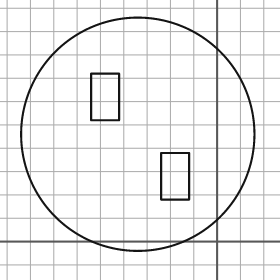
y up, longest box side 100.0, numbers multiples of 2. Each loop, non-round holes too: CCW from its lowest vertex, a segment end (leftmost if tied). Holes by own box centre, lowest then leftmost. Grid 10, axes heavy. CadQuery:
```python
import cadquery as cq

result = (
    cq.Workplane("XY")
    .moveTo(-34.0, 46.0)
    .circle(50.0)
    .moveTo(-24.0, 18.0)
    .lineTo(-12.0, 18.0)
    .lineTo(-12.0, 38.0)
    .lineTo(-24.0, 38.0)
    .close()
    .moveTo(-54.0, 52.0)
    .lineTo(-42.0, 52.0)
    .lineTo(-42.0, 72.0)
    .lineTo(-54.0, 72.0)
    .close()
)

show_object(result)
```